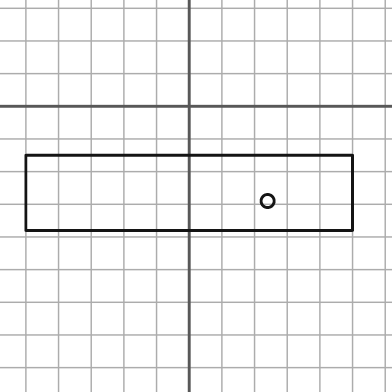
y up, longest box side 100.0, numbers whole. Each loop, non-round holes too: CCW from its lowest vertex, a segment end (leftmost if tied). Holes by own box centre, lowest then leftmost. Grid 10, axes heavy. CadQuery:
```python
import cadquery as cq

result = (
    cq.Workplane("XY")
    .moveTo(-50.0, -38.0)
    .lineTo(50.0, -38.0)
    .lineTo(50.0, -15.0)
    .lineTo(-50.0, -15.0)
    .close()
    .moveTo(24.0, -29.0)
    .circle(2.0)
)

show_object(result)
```